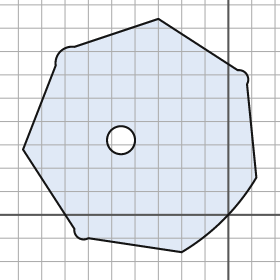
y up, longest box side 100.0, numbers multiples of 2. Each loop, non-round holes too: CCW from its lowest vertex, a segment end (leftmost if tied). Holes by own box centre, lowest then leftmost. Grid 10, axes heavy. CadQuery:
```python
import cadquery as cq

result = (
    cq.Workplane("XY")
    .moveTo(-20.0, -16.0)
    .threePointArc((-2.0, -2.0), (12.0, 16.0))
    .lineTo(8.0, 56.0)
    .threePointArc((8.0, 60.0), (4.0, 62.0))
    .lineTo(-30.0, 84.0)
    .lineTo(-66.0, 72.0)
    .threePointArc((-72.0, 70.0), (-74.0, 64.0))
    .lineTo(-88.0, 28.0)
    .lineTo(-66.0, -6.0)
    .threePointArc((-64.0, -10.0), (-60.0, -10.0))
    .close()
    .moveTo(-46.0, 32.0)
    .circle(6.0)
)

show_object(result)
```